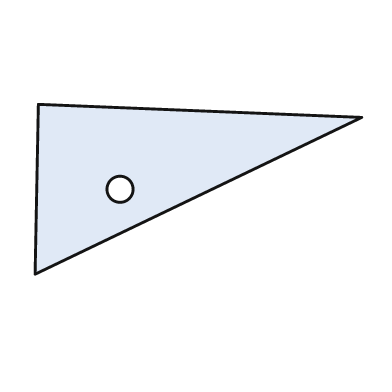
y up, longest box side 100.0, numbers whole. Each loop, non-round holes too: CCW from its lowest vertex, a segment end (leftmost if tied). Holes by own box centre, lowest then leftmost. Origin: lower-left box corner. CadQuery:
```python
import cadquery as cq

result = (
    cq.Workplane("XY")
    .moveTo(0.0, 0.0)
    .lineTo(100.0, 48.0)
    .lineTo(1.0, 52.0)
    .close()
    .moveTo(26.0, 26.0)
    .circle(4.0)
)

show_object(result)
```